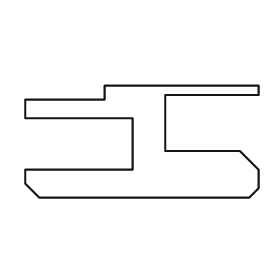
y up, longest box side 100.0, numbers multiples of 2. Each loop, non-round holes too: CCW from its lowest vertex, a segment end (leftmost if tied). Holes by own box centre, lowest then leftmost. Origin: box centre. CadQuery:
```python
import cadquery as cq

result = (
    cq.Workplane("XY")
    .moveTo(-44.0, -24.0)
    .lineTo(46.0, -24.0)
    .lineTo(50.0, -20.0)
    .lineTo(50.0, -12.0)
    .lineTo(42.0, -4.0)
    .lineTo(10.0, -4.0)
    .lineTo(10.0, 20.0)
    .lineTo(50.0, 20.0)
    .lineTo(50.0, 24.0)
    .lineTo(-16.0, 24.0)
    .lineTo(-16.0, 18.0)
    .lineTo(-50.0, 18.0)
    .lineTo(-50.0, 10.0)
    .lineTo(-4.0, 10.0)
    .lineTo(-4.0, -12.0)
    .lineTo(-50.0, -12.0)
    .lineTo(-50.0, -18.0)
    .close()
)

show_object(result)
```